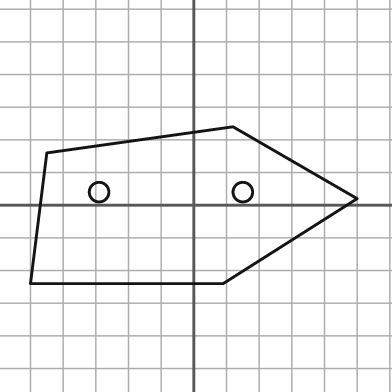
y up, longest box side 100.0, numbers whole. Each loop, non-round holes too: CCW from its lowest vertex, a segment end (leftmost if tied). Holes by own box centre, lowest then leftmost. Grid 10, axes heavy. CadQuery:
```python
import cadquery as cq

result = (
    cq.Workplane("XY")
    .moveTo(-50.0, -24.0)
    .lineTo(9.0, -24.0)
    .lineTo(50.0, 2.0)
    .lineTo(12.0, 24.0)
    .lineTo(-45.0, 16.0)
    .close()
    .moveTo(-29.0, 4.0)
    .circle(3.0)
    .moveTo(15.0, 4.0)
    .circle(3.0)
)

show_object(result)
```